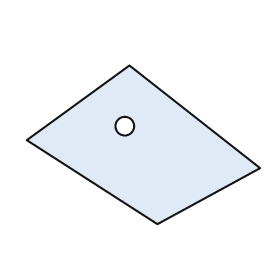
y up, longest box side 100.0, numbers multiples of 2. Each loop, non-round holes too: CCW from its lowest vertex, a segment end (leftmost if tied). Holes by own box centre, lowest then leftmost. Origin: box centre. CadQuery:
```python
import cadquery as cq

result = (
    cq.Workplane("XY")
    .moveTo(6.0, -34.0)
    .lineTo(50.0, -10.0)
    .lineTo(-6.0, 34.0)
    .lineTo(-50.0, 2.0)
    .close()
    .moveTo(-8.0, 8.0)
    .circle(4.0)
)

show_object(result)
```